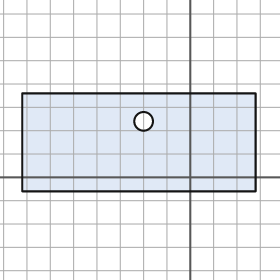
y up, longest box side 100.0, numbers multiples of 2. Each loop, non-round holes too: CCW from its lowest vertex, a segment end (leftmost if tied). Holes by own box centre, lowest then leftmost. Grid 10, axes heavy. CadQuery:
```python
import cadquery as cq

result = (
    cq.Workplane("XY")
    .moveTo(-72.0, -6.0)
    .lineTo(28.0, -6.0)
    .lineTo(28.0, 36.0)
    .lineTo(-72.0, 36.0)
    .close()
    .moveTo(-20.0, 24.0)
    .circle(4.0)
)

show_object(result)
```